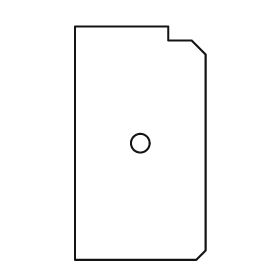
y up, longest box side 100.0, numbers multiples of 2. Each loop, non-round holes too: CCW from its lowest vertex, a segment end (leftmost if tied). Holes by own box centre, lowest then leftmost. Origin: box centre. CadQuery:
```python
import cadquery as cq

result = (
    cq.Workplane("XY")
    .moveTo(-28.0, -50.0)
    .lineTo(24.0, -50.0)
    .lineTo(28.0, -46.0)
    .lineTo(28.0, 38.0)
    .lineTo(22.0, 44.0)
    .lineTo(12.0, 44.0)
    .lineTo(12.0, 50.0)
    .lineTo(-28.0, 50.0)
    .close()
    .moveTo(0.0, 0.0)
    .circle(4.0)
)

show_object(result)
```